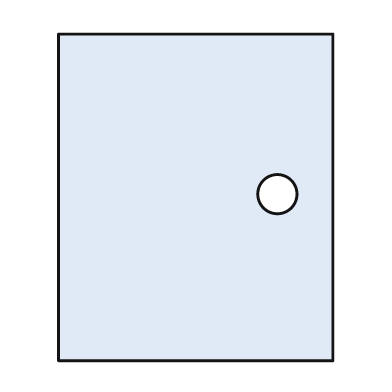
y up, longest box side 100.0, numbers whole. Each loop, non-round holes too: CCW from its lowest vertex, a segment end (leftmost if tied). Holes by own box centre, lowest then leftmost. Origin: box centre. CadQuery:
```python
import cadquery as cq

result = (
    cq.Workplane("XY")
    .moveTo(-42.0, -50.0)
    .lineTo(42.0, -50.0)
    .lineTo(42.0, 50.0)
    .lineTo(-42.0, 50.0)
    .close()
    .moveTo(25.0, 1.0)
    .circle(6.0)
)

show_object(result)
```